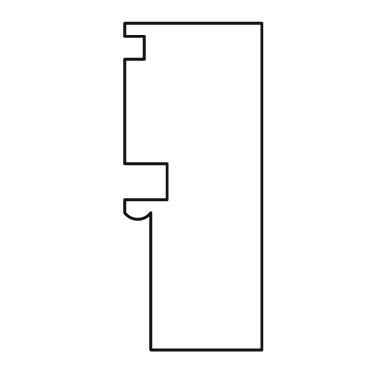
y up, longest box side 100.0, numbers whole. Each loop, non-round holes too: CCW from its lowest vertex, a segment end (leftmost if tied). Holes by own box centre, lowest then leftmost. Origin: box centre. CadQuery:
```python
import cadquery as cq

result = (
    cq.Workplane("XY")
    .moveTo(-13.0, -50.0)
    .lineTo(21.0, -50.0)
    .lineTo(21.0, 50.0)
    .lineTo(-21.0, 50.0)
    .lineTo(-21.0, 46.0)
    .lineTo(-15.0, 46.0)
    .lineTo(-15.0, 39.0)
    .lineTo(-21.0, 39.0)
    .lineTo(-21.0, 7.0)
    .lineTo(-8.0, 7.0)
    .lineTo(-8.0, -4.0)
    .lineTo(-21.0, -4.0)
    .lineTo(-21.0, -8.0)
    .threePointArc((-17.0, -10.0), (-13.0, -8.0))
    .close()
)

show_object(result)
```